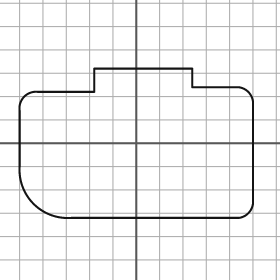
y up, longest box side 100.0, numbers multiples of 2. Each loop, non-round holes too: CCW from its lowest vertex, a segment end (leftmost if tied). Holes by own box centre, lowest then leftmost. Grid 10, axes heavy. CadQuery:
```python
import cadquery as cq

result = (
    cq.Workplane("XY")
    .moveTo(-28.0, -32.0)
    .lineTo(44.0, -32.0)
    .threePointArc((48.0, -30.0), (50.0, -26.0))
    .lineTo(50.0, 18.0)
    .threePointArc((48.0, 22.0), (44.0, 24.0))
    .lineTo(24.0, 24.0)
    .lineTo(24.0, 32.0)
    .lineTo(-18.0, 32.0)
    .lineTo(-18.0, 22.0)
    .lineTo(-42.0, 22.0)
    .threePointArc((-48.0, 20.0), (-50.0, 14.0))
    .lineTo(-50.0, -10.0)
    .threePointArc((-44.0, -26.0), (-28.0, -32.0))
    .close()
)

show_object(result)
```